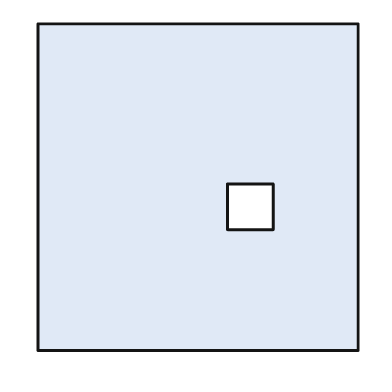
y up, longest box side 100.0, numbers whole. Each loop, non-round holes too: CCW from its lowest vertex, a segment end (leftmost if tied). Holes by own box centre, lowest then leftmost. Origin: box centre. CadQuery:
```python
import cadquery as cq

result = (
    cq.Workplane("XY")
    .moveTo(-49.0, -50.0)
    .lineTo(49.0, -50.0)
    .lineTo(49.0, 50.0)
    .lineTo(-49.0, 50.0)
    .close()
    .moveTo(9.0, -13.0)
    .lineTo(23.0, -13.0)
    .lineTo(23.0, 1.0)
    .lineTo(9.0, 1.0)
    .close()
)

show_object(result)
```